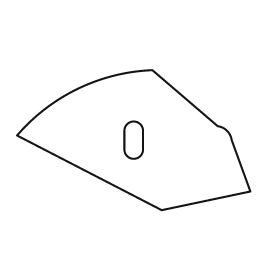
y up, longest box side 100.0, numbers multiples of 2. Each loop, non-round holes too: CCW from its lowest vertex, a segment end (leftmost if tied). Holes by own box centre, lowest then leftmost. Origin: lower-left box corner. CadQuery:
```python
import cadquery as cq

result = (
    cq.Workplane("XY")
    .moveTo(62.0, 0.0)
    .lineTo(100.0, 8.0)
    .lineTo(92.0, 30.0)
    .threePointArc((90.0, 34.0), (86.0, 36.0))
    .lineTo(58.0, 60.0)
    .threePointArc((26.0, 52.0), (0.0, 32.0))
    .close()
    .moveTo(46.0, 26.0)
    .threePointArc((50.0, 22.0), (54.0, 26.0))
    .lineTo(54.0, 34.0)
    .threePointArc((50.0, 38.0), (46.0, 34.0))
    .close()
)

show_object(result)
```